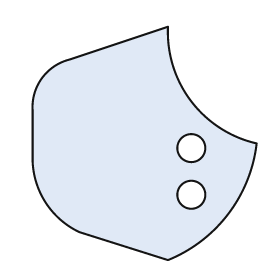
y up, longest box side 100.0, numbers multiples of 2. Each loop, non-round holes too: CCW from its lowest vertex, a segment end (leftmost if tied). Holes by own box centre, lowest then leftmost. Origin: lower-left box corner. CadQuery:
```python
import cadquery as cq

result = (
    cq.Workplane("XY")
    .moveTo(58.0, 0.0)
    .threePointArc((84.0, 20.0), (96.0, 50.0))
    .threePointArc((68.0, 68.0), (58.0, 100.0))
    .lineTo(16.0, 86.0)
    .threePointArc((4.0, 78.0), (0.0, 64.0))
    .lineTo(0.0, 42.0)
    .threePointArc((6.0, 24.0), (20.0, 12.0))
    .close()
    .moveTo(68.0, 28.0)
    .circle(6.0)
    .moveTo(68.0, 48.0)
    .circle(6.0)
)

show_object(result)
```